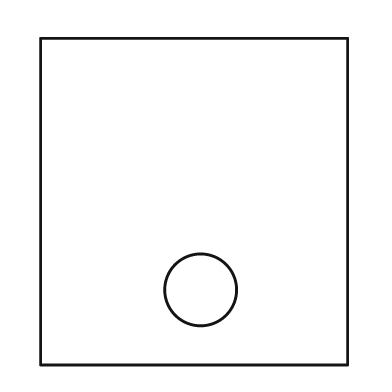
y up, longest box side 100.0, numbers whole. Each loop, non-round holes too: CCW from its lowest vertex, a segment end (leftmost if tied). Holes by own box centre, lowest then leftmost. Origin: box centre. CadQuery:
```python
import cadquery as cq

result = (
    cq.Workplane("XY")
    .moveTo(-47.0, -50.0)
    .lineTo(47.0, -50.0)
    .lineTo(47.0, 50.0)
    .lineTo(-47.0, 50.0)
    .close()
    .moveTo(2.0, -27.0)
    .circle(11.0)
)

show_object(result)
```